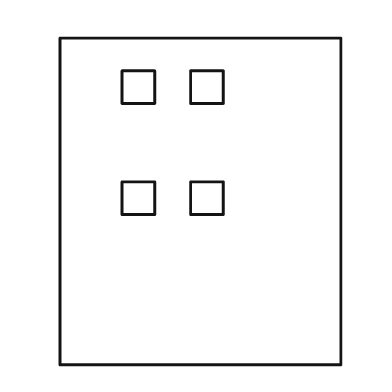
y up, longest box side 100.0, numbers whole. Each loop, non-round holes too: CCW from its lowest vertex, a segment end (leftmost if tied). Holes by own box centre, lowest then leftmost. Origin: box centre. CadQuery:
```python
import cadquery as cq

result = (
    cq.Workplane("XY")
    .moveTo(-43.0, -50.0)
    .lineTo(43.0, -50.0)
    .lineTo(43.0, 50.0)
    .lineTo(-43.0, 50.0)
    .close()
    .moveTo(-24.0, -4.0)
    .lineTo(-14.0, -4.0)
    .lineTo(-14.0, 6.0)
    .lineTo(-24.0, 6.0)
    .close()
    .moveTo(-3.0, -4.0)
    .lineTo(7.0, -4.0)
    .lineTo(7.0, 6.0)
    .lineTo(-3.0, 6.0)
    .close()
    .moveTo(-24.0, 30.0)
    .lineTo(-14.0, 30.0)
    .lineTo(-14.0, 40.0)
    .lineTo(-24.0, 40.0)
    .close()
    .moveTo(-3.0, 30.0)
    .lineTo(7.0, 30.0)
    .lineTo(7.0, 40.0)
    .lineTo(-3.0, 40.0)
    .close()
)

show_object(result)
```